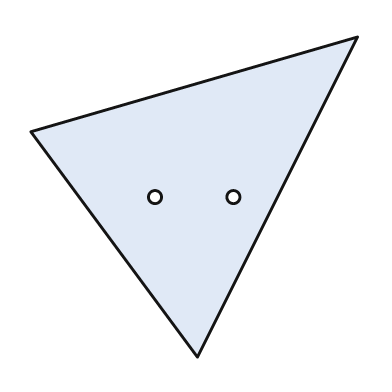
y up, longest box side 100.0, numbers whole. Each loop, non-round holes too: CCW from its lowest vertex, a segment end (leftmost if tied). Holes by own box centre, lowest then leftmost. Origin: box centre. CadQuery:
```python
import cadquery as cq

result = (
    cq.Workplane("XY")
    .moveTo(1.0, -49.0)
    .lineTo(50.0, 49.0)
    .lineTo(-50.0, 20.0)
    .close()
    .moveTo(-12.0, 0.0)
    .circle(2.0)
    .moveTo(12.0, 0.0)
    .circle(2.0)
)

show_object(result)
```